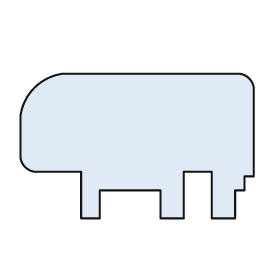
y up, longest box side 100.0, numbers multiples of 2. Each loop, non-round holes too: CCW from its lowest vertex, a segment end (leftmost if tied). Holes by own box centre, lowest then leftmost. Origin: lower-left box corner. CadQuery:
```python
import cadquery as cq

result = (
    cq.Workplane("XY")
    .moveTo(26.0, 0.0)
    .lineTo(34.0, 0.0)
    .lineTo(34.0, 12.0)
    .lineTo(60.0, 12.0)
    .lineTo(60.0, 0.0)
    .lineTo(70.0, 0.0)
    .lineTo(70.0, 20.0)
    .lineTo(82.0, 20.0)
    .lineTo(82.0, 0.0)
    .lineTo(92.0, 0.0)
    .lineTo(92.0, 12.0)
    .lineTo(96.0, 12.0)
    .lineTo(96.0, 18.0)
    .lineTo(100.0, 18.0)
    .lineTo(100.0, 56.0)
    .threePointArc((98.0, 60.0), (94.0, 62.0))
    .lineTo(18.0, 62.0)
    .threePointArc((6.0, 56.0), (0.0, 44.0))
    .lineTo(0.0, 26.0)
    .threePointArc((2.0, 22.0), (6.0, 20.0))
    .lineTo(26.0, 20.0)
    .close()
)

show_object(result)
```